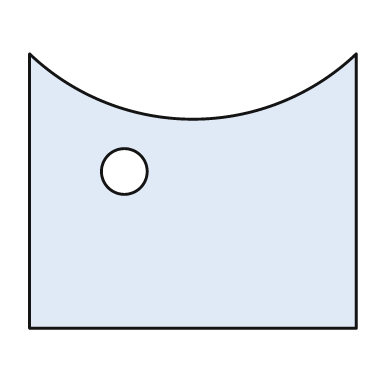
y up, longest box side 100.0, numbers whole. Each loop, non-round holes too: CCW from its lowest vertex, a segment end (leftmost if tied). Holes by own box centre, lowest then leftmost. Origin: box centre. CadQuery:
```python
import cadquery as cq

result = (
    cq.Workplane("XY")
    .moveTo(-50.0, -42.0)
    .lineTo(50.0, -42.0)
    .lineTo(50.0, 42.0)
    .threePointArc((0.0, 22.0), (-50.0, 42.0))
    .close()
    .moveTo(-21.0, 6.0)
    .circle(7.0)
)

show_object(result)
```